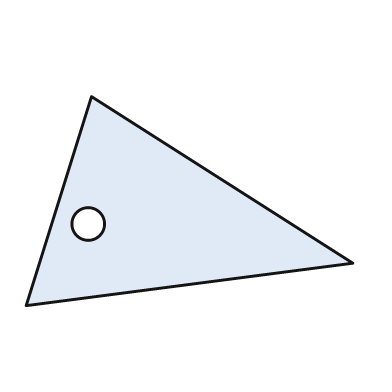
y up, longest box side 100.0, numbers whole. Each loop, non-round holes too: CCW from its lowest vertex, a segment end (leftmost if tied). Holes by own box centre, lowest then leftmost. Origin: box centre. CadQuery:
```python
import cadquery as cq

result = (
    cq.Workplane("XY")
    .moveTo(-50.0, -32.0)
    .lineTo(50.0, -19.0)
    .lineTo(-30.0, 32.0)
    .close()
    .moveTo(-31.0, -7.0)
    .circle(5.0)
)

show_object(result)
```